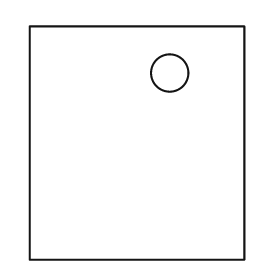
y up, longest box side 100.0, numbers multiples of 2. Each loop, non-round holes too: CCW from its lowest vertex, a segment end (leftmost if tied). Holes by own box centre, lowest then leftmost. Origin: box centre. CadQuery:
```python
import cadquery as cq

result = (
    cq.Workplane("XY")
    .moveTo(-46.0, -50.0)
    .lineTo(46.0, -50.0)
    .lineTo(46.0, 50.0)
    .lineTo(-46.0, 50.0)
    .close()
    .moveTo(14.0, 30.0)
    .circle(8.0)
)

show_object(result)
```